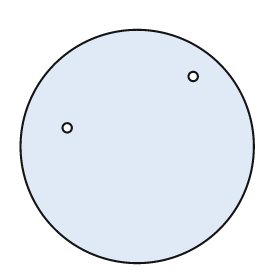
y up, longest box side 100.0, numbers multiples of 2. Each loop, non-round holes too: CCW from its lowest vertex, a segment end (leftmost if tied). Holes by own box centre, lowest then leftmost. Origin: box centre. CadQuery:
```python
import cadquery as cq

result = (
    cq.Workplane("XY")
    .moveTo(0.0, 0.0)
    .circle(50.0)
    .moveTo(-30.0, 8.0)
    .circle(2.0)
    .moveTo(24.0, 30.0)
    .circle(2.0)
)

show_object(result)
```